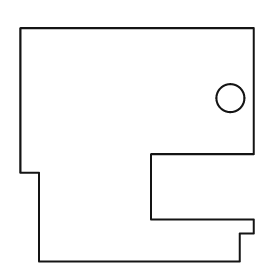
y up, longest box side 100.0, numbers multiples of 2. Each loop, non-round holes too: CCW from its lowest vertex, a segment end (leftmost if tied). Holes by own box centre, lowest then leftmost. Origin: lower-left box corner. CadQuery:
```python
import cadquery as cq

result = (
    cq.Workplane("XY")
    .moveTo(8.0, 0.0)
    .lineTo(94.0, 0.0)
    .lineTo(94.0, 12.0)
    .lineTo(100.0, 12.0)
    .lineTo(100.0, 18.0)
    .lineTo(56.0, 18.0)
    .lineTo(56.0, 46.0)
    .lineTo(100.0, 46.0)
    .lineTo(100.0, 100.0)
    .lineTo(0.0, 100.0)
    .lineTo(0.0, 38.0)
    .lineTo(8.0, 38.0)
    .close()
    .moveTo(90.0, 70.0)
    .circle(6.0)
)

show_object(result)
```